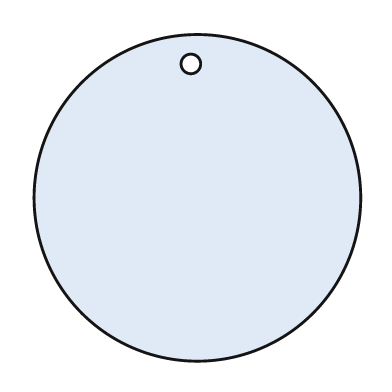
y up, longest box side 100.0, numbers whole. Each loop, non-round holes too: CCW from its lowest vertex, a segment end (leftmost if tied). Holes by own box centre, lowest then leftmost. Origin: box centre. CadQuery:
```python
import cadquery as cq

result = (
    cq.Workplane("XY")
    .moveTo(0.0, 0.0)
    .circle(50.0)
    .moveTo(-2.0, 41.0)
    .circle(3.0)
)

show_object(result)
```